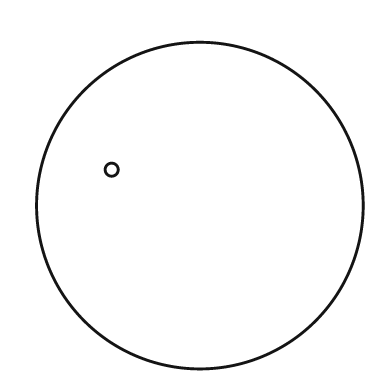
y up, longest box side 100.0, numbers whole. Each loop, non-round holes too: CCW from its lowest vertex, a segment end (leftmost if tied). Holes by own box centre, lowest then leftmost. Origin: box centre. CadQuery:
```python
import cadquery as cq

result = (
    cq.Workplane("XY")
    .moveTo(0.0, 0.0)
    .circle(50.0)
    .moveTo(-27.0, 11.0)
    .circle(2.0)
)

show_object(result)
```